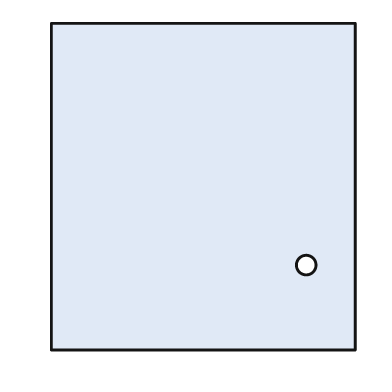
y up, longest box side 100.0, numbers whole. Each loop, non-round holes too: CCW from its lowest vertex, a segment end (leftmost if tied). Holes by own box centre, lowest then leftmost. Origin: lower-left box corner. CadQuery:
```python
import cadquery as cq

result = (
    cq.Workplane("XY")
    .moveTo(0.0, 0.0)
    .lineTo(93.0, 0.0)
    .lineTo(93.0, 100.0)
    .lineTo(0.0, 100.0)
    .close()
    .moveTo(78.0, 26.0)
    .circle(3.0)
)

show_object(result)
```